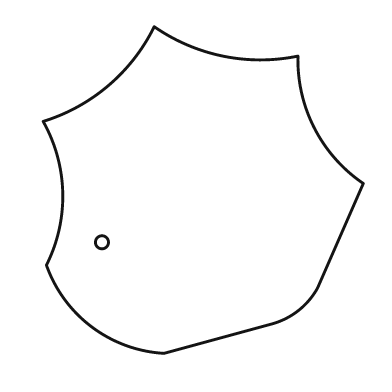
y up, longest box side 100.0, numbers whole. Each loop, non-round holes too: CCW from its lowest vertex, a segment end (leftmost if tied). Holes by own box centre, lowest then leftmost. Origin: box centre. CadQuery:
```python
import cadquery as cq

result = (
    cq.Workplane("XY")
    .moveTo(-12.0, -50.0)
    .lineTo(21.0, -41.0)
    .threePointArc((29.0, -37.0), (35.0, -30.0))
    .lineTo(49.0, 2.0)
    .threePointArc((34.0, 19.0), (29.0, 41.0))
    .threePointArc((6.0, 41.0), (-15.0, 50.0))
    .threePointArc((-29.0, 32.0), (-49.0, 21.0))
    .threePointArc((-43.0, -1.0), (-48.0, -23.0))
    .threePointArc((-34.0, -42.0), (-12.0, -50.0))
    .close()
    .moveTo(-31.0, -16.0)
    .circle(2.0)
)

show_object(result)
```